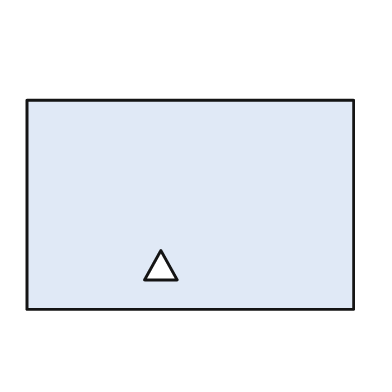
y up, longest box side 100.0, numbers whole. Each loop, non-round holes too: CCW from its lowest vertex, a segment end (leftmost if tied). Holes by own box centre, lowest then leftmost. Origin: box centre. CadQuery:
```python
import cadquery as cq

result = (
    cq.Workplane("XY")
    .moveTo(-50.0, -32.0)
    .lineTo(50.0, -32.0)
    .lineTo(50.0, 32.0)
    .lineTo(-50.0, 32.0)
    .close()
    .moveTo(-14.0, -23.0)
    .lineTo(-4.0, -23.0)
    .lineTo(-9.0, -14.0)
    .close()
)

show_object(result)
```